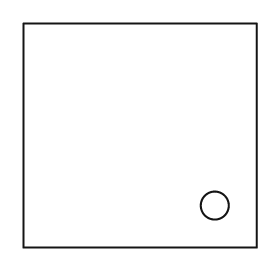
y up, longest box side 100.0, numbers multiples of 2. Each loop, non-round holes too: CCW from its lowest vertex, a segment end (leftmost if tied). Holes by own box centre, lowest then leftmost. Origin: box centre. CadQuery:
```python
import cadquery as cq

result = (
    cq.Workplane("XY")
    .moveTo(-50.0, -48.0)
    .lineTo(50.0, -48.0)
    .lineTo(50.0, 48.0)
    .lineTo(-50.0, 48.0)
    .close()
    .moveTo(32.0, -30.0)
    .circle(6.0)
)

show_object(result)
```